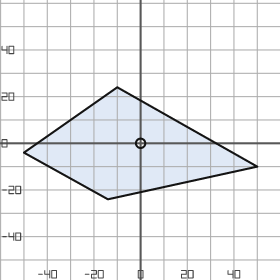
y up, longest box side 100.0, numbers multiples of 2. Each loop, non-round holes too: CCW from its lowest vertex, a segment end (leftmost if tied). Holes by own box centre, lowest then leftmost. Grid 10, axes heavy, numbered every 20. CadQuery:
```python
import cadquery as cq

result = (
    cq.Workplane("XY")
    .moveTo(-14.0, -24.0)
    .lineTo(50.0, -10.0)
    .lineTo(-10.0, 24.0)
    .lineTo(-50.0, -4.0)
    .close()
    .moveTo(0.0, 0.0)
    .circle(2.0)
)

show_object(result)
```